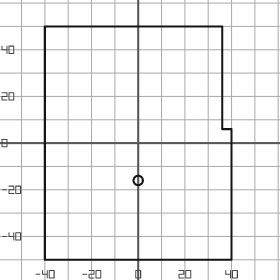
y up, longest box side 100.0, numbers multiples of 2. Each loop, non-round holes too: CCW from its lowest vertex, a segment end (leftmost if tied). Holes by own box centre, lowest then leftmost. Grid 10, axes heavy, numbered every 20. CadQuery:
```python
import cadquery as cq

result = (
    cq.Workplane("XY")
    .moveTo(-40.0, -50.0)
    .lineTo(40.0, -50.0)
    .lineTo(40.0, 6.0)
    .lineTo(36.0, 6.0)
    .lineTo(36.0, 50.0)
    .lineTo(-40.0, 50.0)
    .close()
    .moveTo(0.0, -16.0)
    .circle(2.0)
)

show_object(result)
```